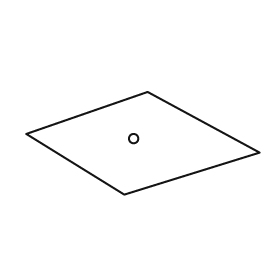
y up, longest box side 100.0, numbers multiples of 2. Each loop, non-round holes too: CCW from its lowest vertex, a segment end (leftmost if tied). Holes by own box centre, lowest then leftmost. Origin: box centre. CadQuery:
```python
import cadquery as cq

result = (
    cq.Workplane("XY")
    .moveTo(-8.0, -22.0)
    .lineTo(50.0, -4.0)
    .lineTo(2.0, 22.0)
    .lineTo(-50.0, 4.0)
    .close()
    .moveTo(-4.0, 2.0)
    .circle(2.0)
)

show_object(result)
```